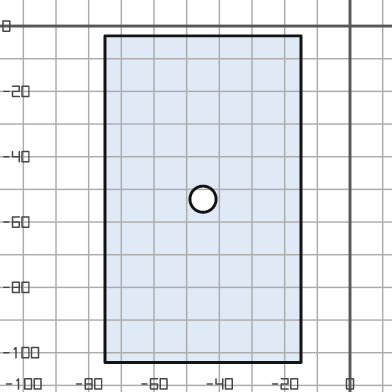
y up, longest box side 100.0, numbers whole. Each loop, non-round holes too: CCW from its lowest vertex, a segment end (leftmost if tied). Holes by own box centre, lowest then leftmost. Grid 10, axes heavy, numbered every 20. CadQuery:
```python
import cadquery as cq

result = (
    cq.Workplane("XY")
    .moveTo(-75.0, -103.0)
    .lineTo(-15.0, -103.0)
    .lineTo(-15.0, -3.0)
    .lineTo(-75.0, -3.0)
    .close()
    .moveTo(-45.0, -53.0)
    .circle(4.0)
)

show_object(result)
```